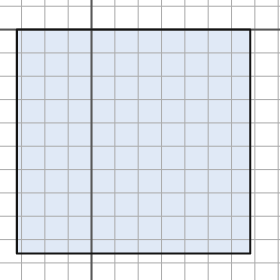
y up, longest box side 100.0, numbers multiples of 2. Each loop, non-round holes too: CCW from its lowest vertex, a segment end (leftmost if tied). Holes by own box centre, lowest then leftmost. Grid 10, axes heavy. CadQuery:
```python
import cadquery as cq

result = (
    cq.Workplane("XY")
    .moveTo(-32.0, -96.0)
    .lineTo(68.0, -96.0)
    .lineTo(68.0, 0.0)
    .lineTo(-32.0, 0.0)
    .close()
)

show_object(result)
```